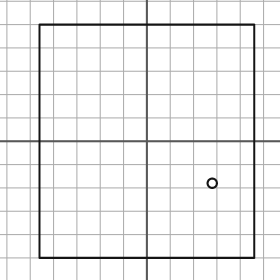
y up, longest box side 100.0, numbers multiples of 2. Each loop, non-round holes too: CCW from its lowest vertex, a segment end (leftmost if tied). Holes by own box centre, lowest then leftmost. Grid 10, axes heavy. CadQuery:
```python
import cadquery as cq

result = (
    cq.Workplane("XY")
    .moveTo(-46.0, -50.0)
    .lineTo(46.0, -50.0)
    .lineTo(46.0, 50.0)
    .lineTo(-46.0, 50.0)
    .close()
    .moveTo(28.0, -18.0)
    .circle(2.0)
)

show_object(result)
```